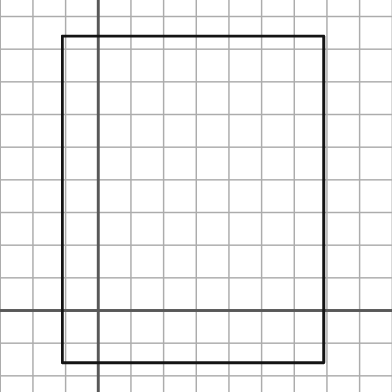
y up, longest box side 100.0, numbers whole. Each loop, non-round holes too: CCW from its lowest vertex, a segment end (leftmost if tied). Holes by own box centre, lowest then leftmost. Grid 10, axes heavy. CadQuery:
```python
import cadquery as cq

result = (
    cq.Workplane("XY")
    .moveTo(-11.0, -16.0)
    .lineTo(69.0, -16.0)
    .lineTo(69.0, 84.0)
    .lineTo(-11.0, 84.0)
    .close()
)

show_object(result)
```